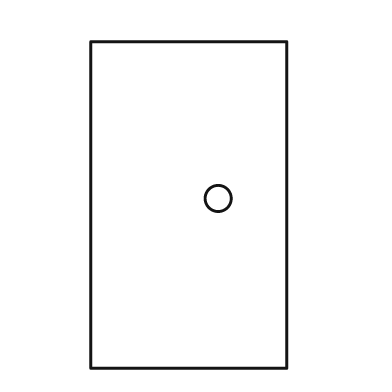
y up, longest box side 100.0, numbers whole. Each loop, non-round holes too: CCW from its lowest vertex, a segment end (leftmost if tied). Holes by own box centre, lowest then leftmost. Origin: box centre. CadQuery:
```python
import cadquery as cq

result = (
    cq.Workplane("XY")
    .moveTo(-30.0, -50.0)
    .lineTo(30.0, -50.0)
    .lineTo(30.0, 50.0)
    .lineTo(-30.0, 50.0)
    .close()
    .moveTo(9.0, 2.0)
    .circle(4.0)
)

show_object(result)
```